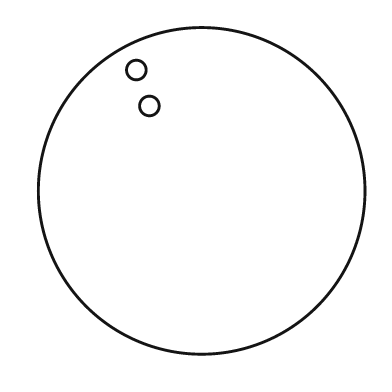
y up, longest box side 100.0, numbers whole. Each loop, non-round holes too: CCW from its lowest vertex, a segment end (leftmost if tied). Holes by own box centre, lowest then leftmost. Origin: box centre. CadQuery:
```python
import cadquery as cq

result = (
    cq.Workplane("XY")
    .moveTo(0.0, 0.0)
    .circle(50.0)
    .moveTo(-16.0, 26.0)
    .circle(3.0)
    .moveTo(-20.0, 37.0)
    .circle(3.0)
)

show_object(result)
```